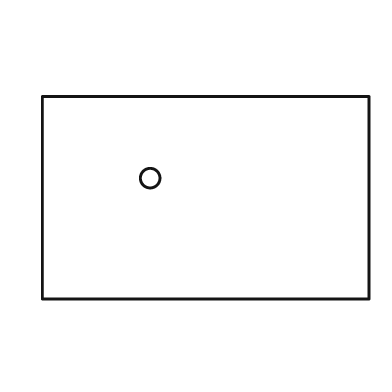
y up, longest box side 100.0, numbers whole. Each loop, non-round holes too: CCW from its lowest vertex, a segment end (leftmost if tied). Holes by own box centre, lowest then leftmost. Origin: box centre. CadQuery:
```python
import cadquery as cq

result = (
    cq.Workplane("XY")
    .moveTo(-50.0, -31.0)
    .lineTo(50.0, -31.0)
    .lineTo(50.0, 31.0)
    .lineTo(-50.0, 31.0)
    .close()
    .moveTo(-17.0, 6.0)
    .circle(3.0)
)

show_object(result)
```